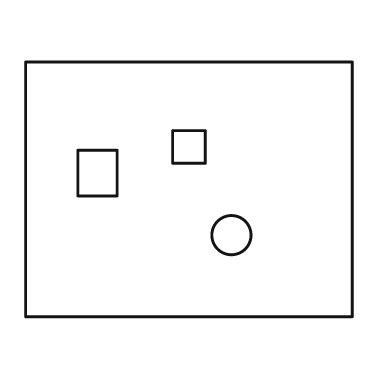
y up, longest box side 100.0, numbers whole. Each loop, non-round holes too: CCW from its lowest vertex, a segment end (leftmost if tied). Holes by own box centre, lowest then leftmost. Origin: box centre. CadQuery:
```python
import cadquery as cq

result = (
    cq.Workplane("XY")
    .moveTo(-50.0, -39.0)
    .lineTo(50.0, -39.0)
    .lineTo(50.0, 39.0)
    .lineTo(-50.0, 39.0)
    .close()
    .moveTo(13.0, -14.0)
    .circle(6.0)
    .moveTo(-34.0, -2.0)
    .lineTo(-22.0, -2.0)
    .lineTo(-22.0, 12.0)
    .lineTo(-34.0, 12.0)
    .close()
    .moveTo(-5.0, 8.0)
    .lineTo(5.0, 8.0)
    .lineTo(5.0, 18.0)
    .lineTo(-5.0, 18.0)
    .close()
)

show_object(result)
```